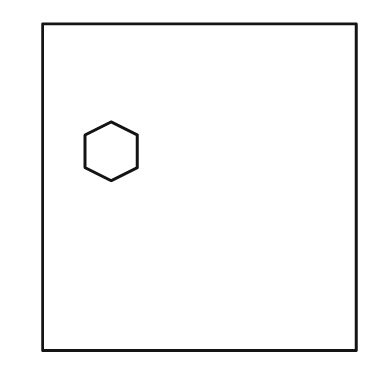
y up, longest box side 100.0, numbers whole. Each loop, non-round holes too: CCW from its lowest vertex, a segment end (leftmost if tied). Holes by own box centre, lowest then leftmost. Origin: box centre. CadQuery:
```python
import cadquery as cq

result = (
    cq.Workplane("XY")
    .moveTo(-48.0, -50.0)
    .lineTo(48.0, -50.0)
    .lineTo(48.0, 50.0)
    .lineTo(-48.0, 50.0)
    .close()
    .moveTo(-27.0, 2.0)
    .lineTo(-19.0, 6.0)
    .lineTo(-19.0, 16.0)
    .lineTo(-27.0, 20.0)
    .lineTo(-35.0, 16.0)
    .lineTo(-35.0, 6.0)
    .close()
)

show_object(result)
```